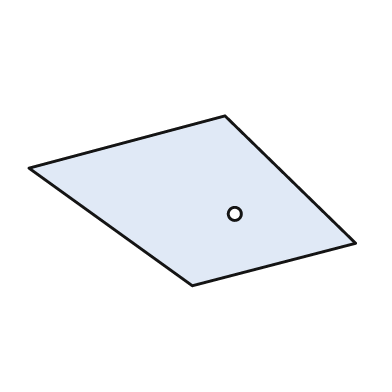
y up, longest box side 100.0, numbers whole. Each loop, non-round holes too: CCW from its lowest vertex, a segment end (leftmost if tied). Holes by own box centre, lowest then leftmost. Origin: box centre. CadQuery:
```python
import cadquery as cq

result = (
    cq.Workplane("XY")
    .moveTo(0.0, -26.0)
    .lineTo(50.0, -13.0)
    .lineTo(10.0, 26.0)
    .lineTo(-50.0, 10.0)
    .close()
    .moveTo(13.0, -4.0)
    .circle(2.0)
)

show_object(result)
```